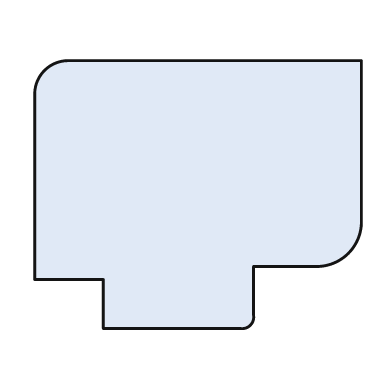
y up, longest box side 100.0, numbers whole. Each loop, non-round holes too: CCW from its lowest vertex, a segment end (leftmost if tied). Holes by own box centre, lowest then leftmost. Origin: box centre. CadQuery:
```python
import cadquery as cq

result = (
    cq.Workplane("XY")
    .moveTo(-29.0, -41.0)
    .lineTo(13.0, -41.0)
    .threePointArc((16.0, -40.0), (17.0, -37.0))
    .lineTo(17.0, -22.0)
    .lineTo(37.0, -22.0)
    .threePointArc((46.0, -18.0), (50.0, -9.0))
    .lineTo(50.0, 41.0)
    .lineTo(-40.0, 41.0)
    .threePointArc((-47.0, 38.0), (-50.0, 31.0))
    .lineTo(-50.0, -26.0)
    .lineTo(-29.0, -26.0)
    .close()
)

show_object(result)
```